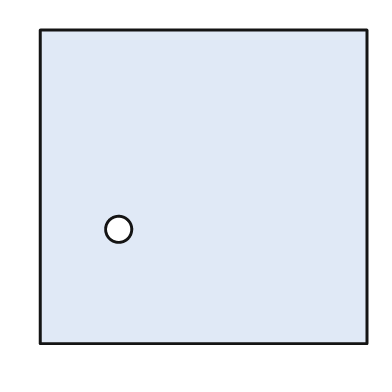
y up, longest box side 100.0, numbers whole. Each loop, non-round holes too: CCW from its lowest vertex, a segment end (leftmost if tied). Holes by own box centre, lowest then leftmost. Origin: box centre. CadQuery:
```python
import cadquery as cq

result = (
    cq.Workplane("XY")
    .moveTo(-50.0, -48.0)
    .lineTo(50.0, -48.0)
    .lineTo(50.0, 48.0)
    .lineTo(-50.0, 48.0)
    .close()
    .moveTo(-26.0, -13.0)
    .circle(4.0)
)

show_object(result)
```